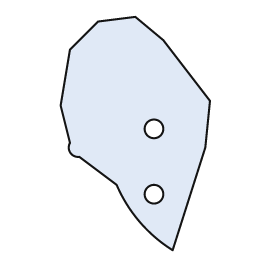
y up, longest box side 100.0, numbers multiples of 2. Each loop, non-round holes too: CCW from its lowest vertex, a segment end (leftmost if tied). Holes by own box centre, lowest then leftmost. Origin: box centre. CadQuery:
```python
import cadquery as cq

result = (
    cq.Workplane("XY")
    .moveTo(16.0, -50.0)
    .lineTo(30.0, -6.0)
    .lineTo(32.0, 14.0)
    .lineTo(12.0, 40.0)
    .lineTo(0.0, 50.0)
    .lineTo(-16.0, 48.0)
    .lineTo(-28.0, 36.0)
    .lineTo(-32.0, 12.0)
    .lineTo(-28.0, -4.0)
    .threePointArc((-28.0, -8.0), (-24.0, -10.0))
    .lineTo(-8.0, -22.0)
    .threePointArc((2.0, -38.0), (16.0, -50.0))
    .close()
    .moveTo(8.0, -26.0)
    .circle(4.0)
    .moveTo(8.0, 2.0)
    .circle(4.0)
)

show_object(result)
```